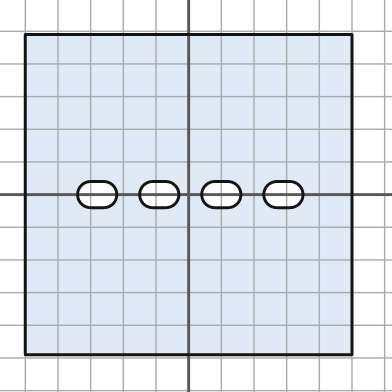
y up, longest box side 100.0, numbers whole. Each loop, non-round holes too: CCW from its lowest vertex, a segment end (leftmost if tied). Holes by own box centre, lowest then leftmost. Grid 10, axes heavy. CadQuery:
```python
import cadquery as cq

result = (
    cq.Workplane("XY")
    .moveTo(-50.0, -49.0)
    .lineTo(50.0, -49.0)
    .lineTo(50.0, 49.0)
    .lineTo(-50.0, 49.0)
    .close()
    .moveTo(-30.0, -4.0)
    .lineTo(-26.0, -4.0)
    .threePointArc((-22.0, 0.0), (-26.0, 4.0))
    .lineTo(-30.0, 4.0)
    .threePointArc((-34.0, 0.0), (-30.0, -4.0))
    .close()
    .moveTo(-11.0, -4.0)
    .lineTo(-7.0, -4.0)
    .threePointArc((-3.0, 0.0), (-7.0, 4.0))
    .lineTo(-11.0, 4.0)
    .threePointArc((-15.0, 0.0), (-11.0, -4.0))
    .close()
    .moveTo(8.0, -4.0)
    .lineTo(12.0, -4.0)
    .threePointArc((16.0, 0.0), (12.0, 4.0))
    .lineTo(8.0, 4.0)
    .threePointArc((4.0, 0.0), (8.0, -4.0))
    .close()
    .moveTo(27.0, -4.0)
    .lineTo(31.0, -4.0)
    .threePointArc((35.0, 0.0), (31.0, 4.0))
    .lineTo(27.0, 4.0)
    .threePointArc((23.0, 0.0), (27.0, -4.0))
    .close()
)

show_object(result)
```